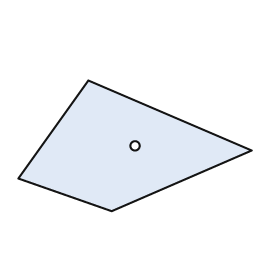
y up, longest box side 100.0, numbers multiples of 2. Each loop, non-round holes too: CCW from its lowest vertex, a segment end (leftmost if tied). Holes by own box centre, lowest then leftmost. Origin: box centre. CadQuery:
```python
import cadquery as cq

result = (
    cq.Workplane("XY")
    .moveTo(-10.0, -28.0)
    .lineTo(50.0, -2.0)
    .lineTo(-20.0, 28.0)
    .lineTo(-50.0, -14.0)
    .close()
    .moveTo(0.0, 0.0)
    .circle(2.0)
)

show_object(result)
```